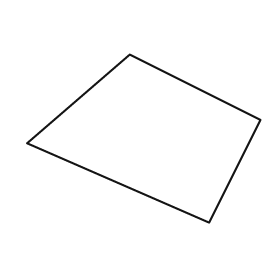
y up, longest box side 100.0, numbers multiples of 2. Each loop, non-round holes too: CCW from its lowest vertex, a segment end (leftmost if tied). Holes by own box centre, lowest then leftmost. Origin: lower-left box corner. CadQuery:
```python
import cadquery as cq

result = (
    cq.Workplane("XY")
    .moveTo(78.0, 0.0)
    .lineTo(100.0, 44.0)
    .lineTo(44.0, 72.0)
    .lineTo(0.0, 34.0)
    .close()
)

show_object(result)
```